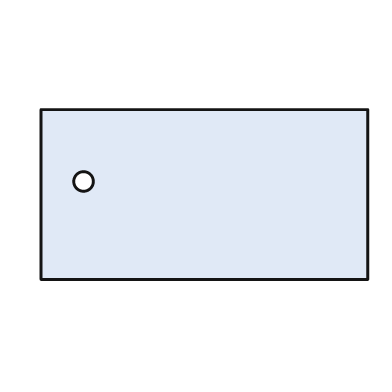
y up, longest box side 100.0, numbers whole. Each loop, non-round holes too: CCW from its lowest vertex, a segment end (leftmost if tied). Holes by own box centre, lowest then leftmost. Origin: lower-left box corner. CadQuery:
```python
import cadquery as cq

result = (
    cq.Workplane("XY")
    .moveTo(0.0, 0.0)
    .lineTo(100.0, 0.0)
    .lineTo(100.0, 52.0)
    .lineTo(0.0, 52.0)
    .close()
    .moveTo(13.0, 30.0)
    .circle(3.0)
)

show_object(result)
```